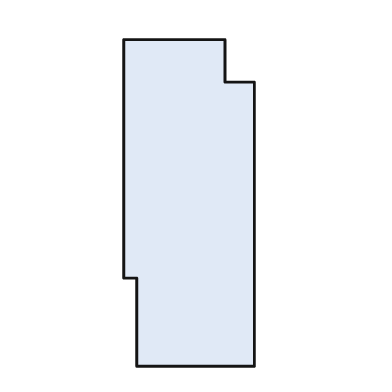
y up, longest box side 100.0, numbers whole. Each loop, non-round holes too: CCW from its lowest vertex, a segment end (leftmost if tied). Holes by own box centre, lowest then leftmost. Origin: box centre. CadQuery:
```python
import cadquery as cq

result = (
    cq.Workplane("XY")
    .moveTo(-16.0, -50.0)
    .lineTo(20.0, -50.0)
    .lineTo(20.0, 37.0)
    .lineTo(11.0, 37.0)
    .lineTo(11.0, 50.0)
    .lineTo(-20.0, 50.0)
    .lineTo(-20.0, -23.0)
    .lineTo(-16.0, -23.0)
    .close()
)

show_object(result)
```